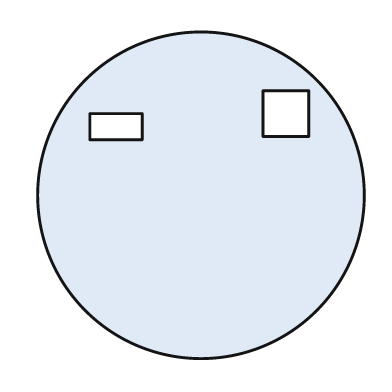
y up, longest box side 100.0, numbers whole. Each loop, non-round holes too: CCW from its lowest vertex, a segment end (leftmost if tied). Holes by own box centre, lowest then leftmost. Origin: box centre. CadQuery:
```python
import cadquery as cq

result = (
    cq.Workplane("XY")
    .moveTo(0.0, 0.0)
    .circle(50.0)
    .moveTo(-34.0, 17.0)
    .lineTo(-18.0, 17.0)
    .lineTo(-18.0, 25.0)
    .lineTo(-34.0, 25.0)
    .close()
    .moveTo(19.0, 18.0)
    .lineTo(33.0, 18.0)
    .lineTo(33.0, 32.0)
    .lineTo(19.0, 32.0)
    .close()
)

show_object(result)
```